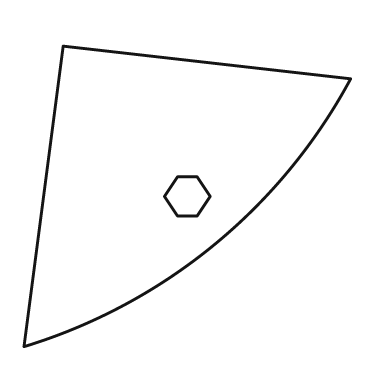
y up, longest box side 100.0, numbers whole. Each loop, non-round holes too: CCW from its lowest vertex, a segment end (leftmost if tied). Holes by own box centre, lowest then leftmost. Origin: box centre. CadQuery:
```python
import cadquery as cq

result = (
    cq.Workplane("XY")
    .moveTo(-50.0, -46.0)
    .threePointArc((8.0, -15.0), (50.0, 36.0))
    .lineTo(-38.0, 46.0)
    .close()
    .moveTo(-3.0, -6.0)
    .lineTo(3.0, -6.0)
    .lineTo(7.0, 0.0)
    .lineTo(3.0, 6.0)
    .lineTo(-3.0, 6.0)
    .lineTo(-7.0, 0.0)
    .close()
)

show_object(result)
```